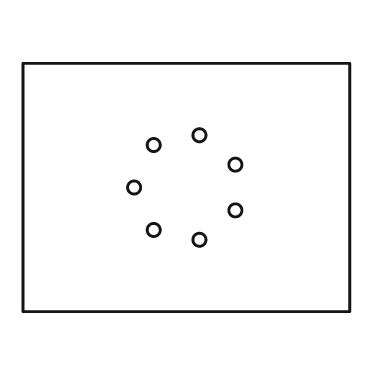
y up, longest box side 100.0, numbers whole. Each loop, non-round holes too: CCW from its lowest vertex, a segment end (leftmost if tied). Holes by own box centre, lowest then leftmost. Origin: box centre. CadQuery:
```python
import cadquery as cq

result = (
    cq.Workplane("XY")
    .moveTo(-50.0, -38.0)
    .lineTo(50.0, -38.0)
    .lineTo(50.0, 38.0)
    .lineTo(-50.0, 38.0)
    .close()
    .moveTo(4.0, -16.0)
    .circle(2.0)
    .moveTo(-10.0, -13.0)
    .circle(2.0)
    .moveTo(15.0, -7.0)
    .circle(2.0)
    .moveTo(-16.0, 0.0)
    .circle(2.0)
    .moveTo(15.0, 7.0)
    .circle(2.0)
    .moveTo(-10.0, 13.0)
    .circle(2.0)
    .moveTo(4.0, 16.0)
    .circle(2.0)
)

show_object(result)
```